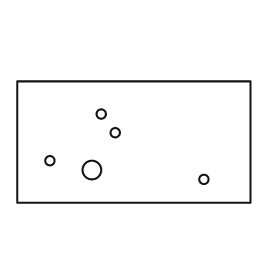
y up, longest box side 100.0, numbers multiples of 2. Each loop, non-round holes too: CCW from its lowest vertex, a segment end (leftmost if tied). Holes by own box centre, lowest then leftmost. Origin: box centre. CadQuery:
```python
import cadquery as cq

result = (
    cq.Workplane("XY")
    .moveTo(-50.0, -26.0)
    .lineTo(50.0, -26.0)
    .lineTo(50.0, 26.0)
    .lineTo(-50.0, 26.0)
    .close()
    .moveTo(30.0, -16.0)
    .circle(2.0)
    .moveTo(-18.0, -12.0)
    .circle(4.0)
    .moveTo(-36.0, -8.0)
    .circle(2.0)
    .moveTo(-8.0, 4.0)
    .circle(2.0)
    .moveTo(-14.0, 12.0)
    .circle(2.0)
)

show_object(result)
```